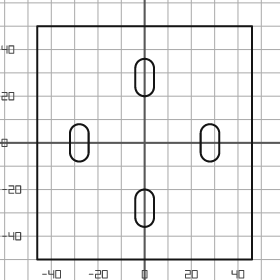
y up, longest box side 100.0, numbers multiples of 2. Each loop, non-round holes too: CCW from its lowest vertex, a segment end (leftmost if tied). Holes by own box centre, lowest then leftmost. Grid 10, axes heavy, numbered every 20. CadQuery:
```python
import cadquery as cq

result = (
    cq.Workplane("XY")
    .moveTo(-46.0, -50.0)
    .lineTo(46.0, -50.0)
    .lineTo(46.0, 50.0)
    .lineTo(-46.0, 50.0)
    .close()
    .moveTo(-4.0, -32.0)
    .threePointArc((0.0, -36.0), (4.0, -32.0))
    .lineTo(4.0, -24.0)
    .threePointArc((0.0, -20.0), (-4.0, -24.0))
    .close()
    .moveTo(-32.0, -4.0)
    .threePointArc((-28.0, -8.0), (-24.0, -4.0))
    .lineTo(-24.0, 4.0)
    .threePointArc((-28.0, 8.0), (-32.0, 4.0))
    .close()
    .moveTo(24.0, -4.0)
    .threePointArc((28.0, -8.0), (32.0, -4.0))
    .lineTo(32.0, 4.0)
    .threePointArc((28.0, 8.0), (24.0, 4.0))
    .close()
    .moveTo(-4.0, 24.0)
    .threePointArc((0.0, 20.0), (4.0, 24.0))
    .lineTo(4.0, 32.0)
    .threePointArc((0.0, 36.0), (-4.0, 32.0))
    .close()
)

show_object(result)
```